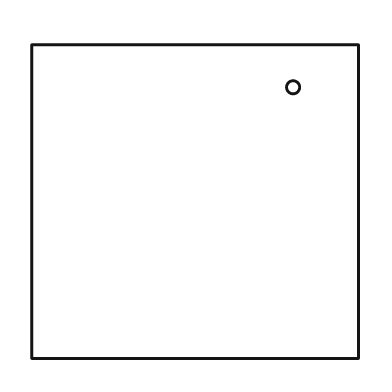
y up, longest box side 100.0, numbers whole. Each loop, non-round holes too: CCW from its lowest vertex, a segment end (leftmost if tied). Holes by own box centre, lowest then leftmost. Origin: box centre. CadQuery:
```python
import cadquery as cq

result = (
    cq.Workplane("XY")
    .moveTo(-50.0, -48.0)
    .lineTo(50.0, -48.0)
    .lineTo(50.0, 48.0)
    .lineTo(-50.0, 48.0)
    .close()
    .moveTo(30.0, 35.0)
    .circle(2.0)
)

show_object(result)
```